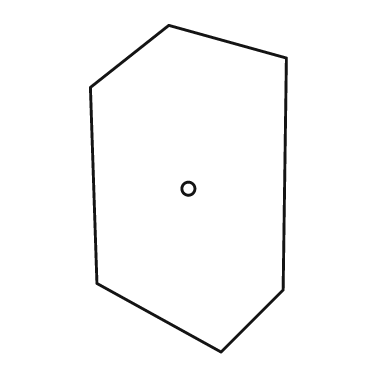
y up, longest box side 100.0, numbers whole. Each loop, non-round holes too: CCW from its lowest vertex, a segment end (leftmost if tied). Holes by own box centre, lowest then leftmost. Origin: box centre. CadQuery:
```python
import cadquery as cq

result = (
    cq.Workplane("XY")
    .moveTo(10.0, -50.0)
    .lineTo(29.0, -31.0)
    .lineTo(30.0, 40.0)
    .lineTo(-6.0, 50.0)
    .lineTo(-30.0, 31.0)
    .lineTo(-28.0, -29.0)
    .close()
    .moveTo(0.0, 0.0)
    .circle(2.0)
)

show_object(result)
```